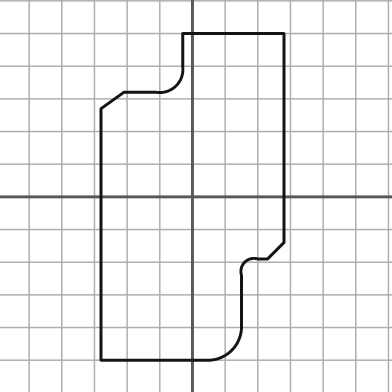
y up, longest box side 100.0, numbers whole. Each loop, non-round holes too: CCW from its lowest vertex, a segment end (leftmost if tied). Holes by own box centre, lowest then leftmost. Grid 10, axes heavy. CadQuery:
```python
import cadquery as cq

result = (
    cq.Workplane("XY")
    .moveTo(-28.0, -50.0)
    .lineTo(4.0, -50.0)
    .threePointArc((12.0, -47.0), (15.0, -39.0))
    .lineTo(15.0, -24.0)
    .threePointArc((16.0, -20.0), (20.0, -19.0))
    .lineTo(23.0, -19.0)
    .lineTo(28.0, -14.0)
    .lineTo(28.0, 50.0)
    .lineTo(-3.0, 50.0)
    .lineTo(-3.0, 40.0)
    .threePointArc((-5.0, 34.0), (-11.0, 32.0))
    .lineTo(-21.0, 32.0)
    .lineTo(-28.0, 27.0)
    .close()
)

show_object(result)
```